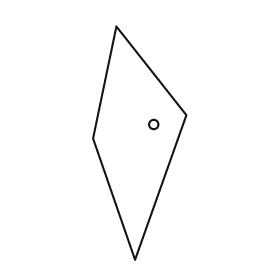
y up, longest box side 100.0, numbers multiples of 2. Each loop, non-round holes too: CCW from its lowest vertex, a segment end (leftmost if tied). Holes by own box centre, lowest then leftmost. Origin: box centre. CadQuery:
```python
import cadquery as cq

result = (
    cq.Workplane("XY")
    .moveTo(-2.0, -50.0)
    .lineTo(20.0, 12.0)
    .lineTo(-10.0, 50.0)
    .lineTo(-20.0, 2.0)
    .close()
    .moveTo(6.0, 8.0)
    .circle(2.0)
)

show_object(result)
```